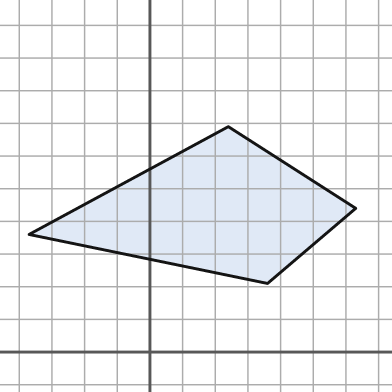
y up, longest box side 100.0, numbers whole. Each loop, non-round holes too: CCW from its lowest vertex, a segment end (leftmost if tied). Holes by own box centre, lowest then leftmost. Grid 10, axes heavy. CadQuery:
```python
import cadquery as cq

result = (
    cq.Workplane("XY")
    .moveTo(36.0, 21.0)
    .lineTo(63.0, 44.0)
    .lineTo(24.0, 69.0)
    .lineTo(-37.0, 36.0)
    .close()
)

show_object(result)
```